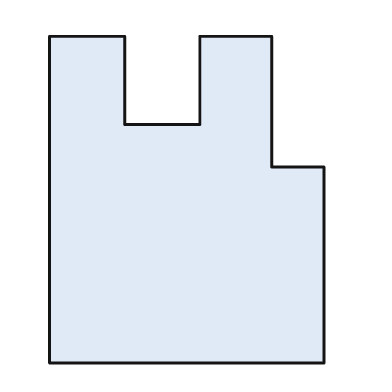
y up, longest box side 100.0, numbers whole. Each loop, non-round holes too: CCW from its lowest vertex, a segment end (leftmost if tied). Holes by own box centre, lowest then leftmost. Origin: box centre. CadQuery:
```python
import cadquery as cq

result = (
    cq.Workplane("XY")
    .moveTo(-42.0, -50.0)
    .lineTo(42.0, -50.0)
    .lineTo(42.0, 10.0)
    .lineTo(26.0, 10.0)
    .lineTo(26.0, 50.0)
    .lineTo(4.0, 50.0)
    .lineTo(4.0, 23.0)
    .lineTo(-19.0, 23.0)
    .lineTo(-19.0, 50.0)
    .lineTo(-42.0, 50.0)
    .close()
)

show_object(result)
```